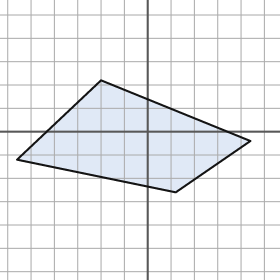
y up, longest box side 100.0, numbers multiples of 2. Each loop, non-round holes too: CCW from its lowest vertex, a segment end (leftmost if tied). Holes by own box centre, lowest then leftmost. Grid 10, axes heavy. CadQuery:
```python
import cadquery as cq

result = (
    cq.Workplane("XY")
    .moveTo(12.0, -26.0)
    .lineTo(44.0, -4.0)
    .lineTo(-20.0, 22.0)
    .lineTo(-56.0, -12.0)
    .close()
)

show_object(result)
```